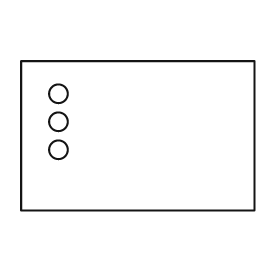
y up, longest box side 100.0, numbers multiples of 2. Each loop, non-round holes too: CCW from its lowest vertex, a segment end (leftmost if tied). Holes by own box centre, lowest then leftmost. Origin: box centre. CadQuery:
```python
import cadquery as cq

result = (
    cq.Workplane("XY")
    .moveTo(-50.0, -32.0)
    .lineTo(50.0, -32.0)
    .lineTo(50.0, 32.0)
    .lineTo(-50.0, 32.0)
    .close()
    .moveTo(-34.0, -6.0)
    .circle(4.0)
    .moveTo(-34.0, 6.0)
    .circle(4.0)
    .moveTo(-34.0, 18.0)
    .circle(4.0)
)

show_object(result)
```